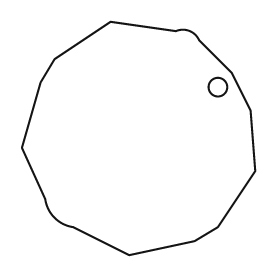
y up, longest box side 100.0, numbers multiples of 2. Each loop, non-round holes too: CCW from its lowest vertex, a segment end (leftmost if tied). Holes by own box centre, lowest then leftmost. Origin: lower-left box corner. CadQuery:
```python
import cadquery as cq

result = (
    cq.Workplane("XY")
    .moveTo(46.0, 0.0)
    .lineTo(74.0, 6.0)
    .lineTo(84.0, 12.0)
    .lineTo(100.0, 36.0)
    .lineTo(98.0, 62.0)
    .lineTo(90.0, 78.0)
    .lineTo(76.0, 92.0)
    .threePointArc((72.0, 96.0), (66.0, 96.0))
    .lineTo(38.0, 100.0)
    .lineTo(14.0, 84.0)
    .lineTo(8.0, 74.0)
    .lineTo(0.0, 46.0)
    .lineTo(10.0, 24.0)
    .threePointArc((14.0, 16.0), (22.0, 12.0))
    .close()
    .moveTo(84.0, 72.0)
    .circle(4.0)
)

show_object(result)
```